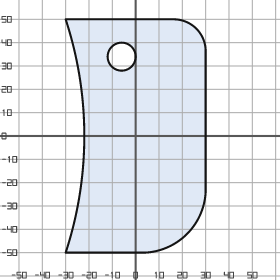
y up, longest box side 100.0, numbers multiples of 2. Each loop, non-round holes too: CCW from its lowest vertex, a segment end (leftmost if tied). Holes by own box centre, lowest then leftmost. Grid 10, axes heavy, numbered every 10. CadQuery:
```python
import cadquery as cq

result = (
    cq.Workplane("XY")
    .moveTo(-30.0, -50.0)
    .lineTo(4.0, -50.0)
    .threePointArc((22.0, -42.0), (30.0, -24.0))
    .lineTo(30.0, 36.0)
    .threePointArc((26.0, 46.0), (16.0, 50.0))
    .lineTo(-30.0, 50.0)
    .threePointArc((-22.0, 0.0), (-30.0, -50.0))
    .close()
    .moveTo(-6.0, 34.0)
    .circle(6.0)
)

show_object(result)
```